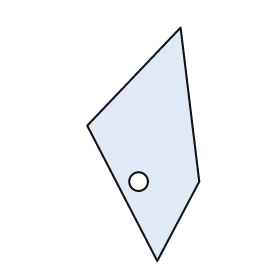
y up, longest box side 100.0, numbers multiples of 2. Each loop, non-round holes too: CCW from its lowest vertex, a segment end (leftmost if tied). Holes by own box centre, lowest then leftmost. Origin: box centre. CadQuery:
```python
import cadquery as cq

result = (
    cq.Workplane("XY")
    .moveTo(6.0, -50.0)
    .lineTo(24.0, -16.0)
    .lineTo(16.0, 50.0)
    .lineTo(-24.0, 8.0)
    .close()
    .moveTo(-2.0, -16.0)
    .circle(4.0)
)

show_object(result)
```